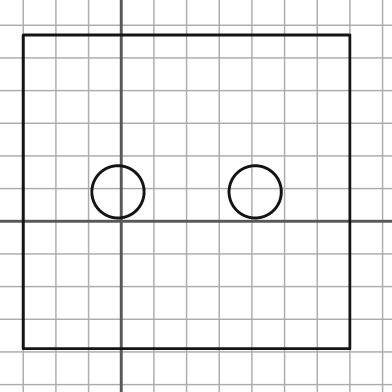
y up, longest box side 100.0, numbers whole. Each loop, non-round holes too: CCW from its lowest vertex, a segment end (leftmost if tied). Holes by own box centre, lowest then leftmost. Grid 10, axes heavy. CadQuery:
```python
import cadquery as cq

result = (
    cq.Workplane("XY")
    .moveTo(-30.0, -39.0)
    .lineTo(70.0, -39.0)
    .lineTo(70.0, 57.0)
    .lineTo(-30.0, 57.0)
    .close()
    .moveTo(-1.0, 9.0)
    .circle(8.0)
    .moveTo(41.0, 9.0)
    .circle(8.0)
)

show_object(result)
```